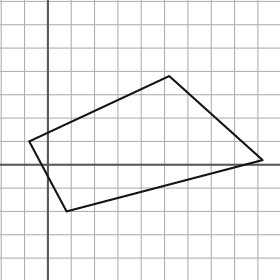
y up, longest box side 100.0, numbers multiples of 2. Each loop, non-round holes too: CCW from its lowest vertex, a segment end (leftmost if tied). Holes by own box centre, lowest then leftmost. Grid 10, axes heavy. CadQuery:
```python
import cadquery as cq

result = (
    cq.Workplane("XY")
    .moveTo(8.0, -20.0)
    .lineTo(92.0, 2.0)
    .lineTo(52.0, 38.0)
    .lineTo(-8.0, 10.0)
    .close()
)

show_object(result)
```